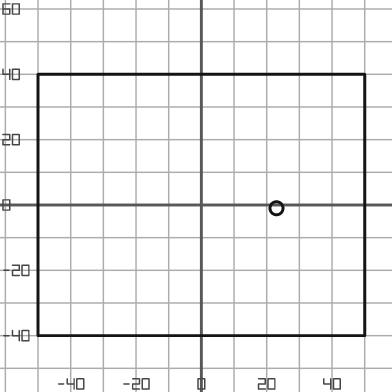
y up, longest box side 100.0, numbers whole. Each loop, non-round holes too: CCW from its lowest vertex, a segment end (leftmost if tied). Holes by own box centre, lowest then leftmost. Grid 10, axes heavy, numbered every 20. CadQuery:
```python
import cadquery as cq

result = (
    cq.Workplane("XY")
    .moveTo(-50.0, -40.0)
    .lineTo(50.0, -40.0)
    .lineTo(50.0, 40.0)
    .lineTo(-50.0, 40.0)
    .close()
    .moveTo(23.0, -1.0)
    .circle(2.0)
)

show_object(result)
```